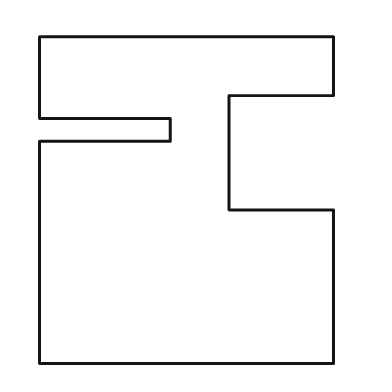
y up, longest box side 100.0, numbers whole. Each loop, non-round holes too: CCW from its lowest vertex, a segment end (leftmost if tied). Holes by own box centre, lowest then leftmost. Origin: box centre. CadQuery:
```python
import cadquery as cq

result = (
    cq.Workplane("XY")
    .moveTo(-45.0, -50.0)
    .lineTo(45.0, -50.0)
    .lineTo(45.0, -3.0)
    .lineTo(13.0, -3.0)
    .lineTo(13.0, 32.0)
    .lineTo(45.0, 32.0)
    .lineTo(45.0, 50.0)
    .lineTo(-45.0, 50.0)
    .lineTo(-45.0, 25.0)
    .lineTo(-5.0, 25.0)
    .lineTo(-5.0, 18.0)
    .lineTo(-45.0, 18.0)
    .close()
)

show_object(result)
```